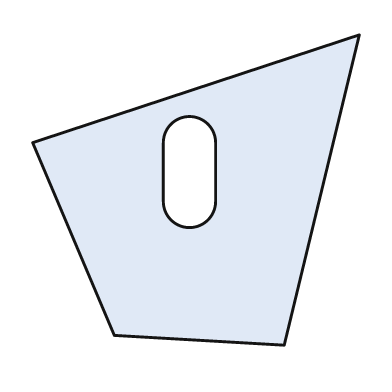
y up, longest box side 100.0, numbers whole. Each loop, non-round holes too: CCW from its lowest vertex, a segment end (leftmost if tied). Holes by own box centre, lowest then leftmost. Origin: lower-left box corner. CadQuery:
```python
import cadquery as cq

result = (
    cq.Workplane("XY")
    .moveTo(77.0, 0.0)
    .lineTo(100.0, 95.0)
    .lineTo(0.0, 62.0)
    .lineTo(25.0, 3.0)
    .close()
    .moveTo(40.0, 44.0)
    .threePointArc((48.0, 36.0), (56.0, 44.0))
    .lineTo(56.0, 62.0)
    .threePointArc((48.0, 70.0), (40.0, 62.0))
    .close()
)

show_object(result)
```